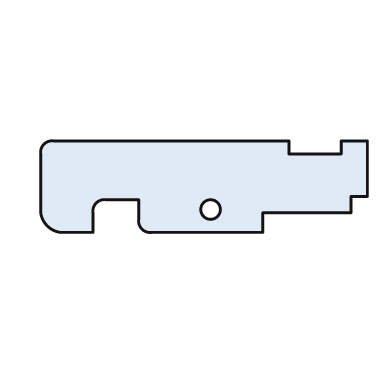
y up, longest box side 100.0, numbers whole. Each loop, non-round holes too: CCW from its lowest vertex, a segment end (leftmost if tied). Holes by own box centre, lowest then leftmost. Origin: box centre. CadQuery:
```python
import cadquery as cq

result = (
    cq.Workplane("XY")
    .moveTo(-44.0, -14.0)
    .lineTo(-34.0, -14.0)
    .lineTo(-34.0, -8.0)
    .threePointArc((-33.0, -5.0), (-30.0, -4.0))
    .lineTo(-20.0, -4.0)
    .lineTo(-20.0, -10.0)
    .threePointArc((-19.0, -13.0), (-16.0, -14.0))
    .lineTo(18.0, -14.0)
    .lineTo(18.0, -8.0)
    .lineTo(45.0, -8.0)
    .lineTo(45.0, -3.0)
    .lineTo(50.0, -3.0)
    .lineTo(50.0, 14.0)
    .lineTo(42.0, 14.0)
    .lineTo(42.0, 10.0)
    .lineTo(26.0, 10.0)
    .lineTo(26.0, 14.0)
    .lineTo(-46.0, 14.0)
    .threePointArc((-49.0, 13.0), (-50.0, 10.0))
    .lineTo(-50.0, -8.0)
    .threePointArc((-48.0, -12.0), (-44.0, -14.0))
    .close()
    .moveTo(2.0, -7.0)
    .circle(3.0)
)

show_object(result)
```